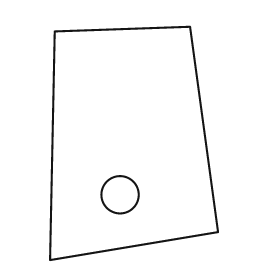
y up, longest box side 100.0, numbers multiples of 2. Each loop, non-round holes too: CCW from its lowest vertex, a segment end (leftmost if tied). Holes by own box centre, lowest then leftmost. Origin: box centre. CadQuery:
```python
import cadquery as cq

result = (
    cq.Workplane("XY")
    .moveTo(-36.0, -50.0)
    .lineTo(36.0, -38.0)
    .lineTo(24.0, 50.0)
    .lineTo(-34.0, 48.0)
    .close()
    .moveTo(-6.0, -22.0)
    .circle(8.0)
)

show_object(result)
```